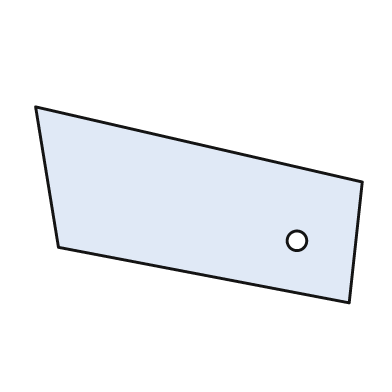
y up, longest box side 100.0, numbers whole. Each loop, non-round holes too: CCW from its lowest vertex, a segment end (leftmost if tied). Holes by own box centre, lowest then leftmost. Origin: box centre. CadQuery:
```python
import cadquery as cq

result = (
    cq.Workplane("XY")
    .moveTo(46.0, -30.0)
    .lineTo(50.0, 7.0)
    .lineTo(-50.0, 30.0)
    .lineTo(-43.0, -13.0)
    .close()
    .moveTo(30.0, -11.0)
    .circle(3.0)
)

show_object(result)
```